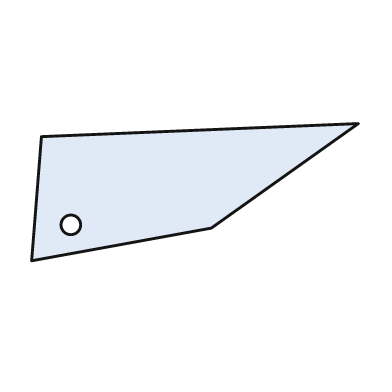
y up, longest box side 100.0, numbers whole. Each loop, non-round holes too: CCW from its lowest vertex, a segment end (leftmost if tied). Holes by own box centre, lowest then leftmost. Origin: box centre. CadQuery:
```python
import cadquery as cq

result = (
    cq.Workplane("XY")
    .moveTo(-50.0, -21.0)
    .lineTo(5.0, -11.0)
    .lineTo(50.0, 21.0)
    .lineTo(-47.0, 17.0)
    .close()
    .moveTo(-38.0, -10.0)
    .circle(3.0)
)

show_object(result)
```